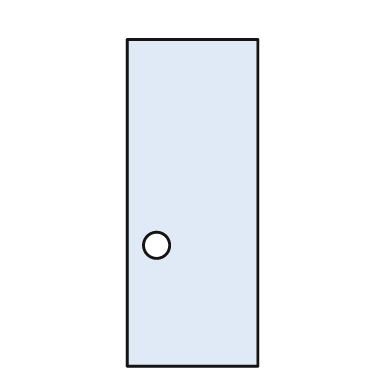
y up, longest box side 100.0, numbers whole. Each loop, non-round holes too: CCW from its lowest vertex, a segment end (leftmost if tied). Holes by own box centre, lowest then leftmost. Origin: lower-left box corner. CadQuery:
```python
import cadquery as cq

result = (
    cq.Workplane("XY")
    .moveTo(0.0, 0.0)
    .lineTo(40.0, 0.0)
    .lineTo(40.0, 100.0)
    .lineTo(0.0, 100.0)
    .close()
    .moveTo(9.0, 37.0)
    .circle(4.0)
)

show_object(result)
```